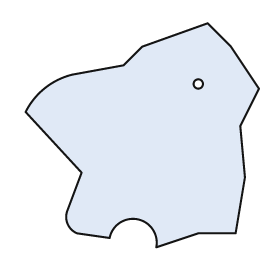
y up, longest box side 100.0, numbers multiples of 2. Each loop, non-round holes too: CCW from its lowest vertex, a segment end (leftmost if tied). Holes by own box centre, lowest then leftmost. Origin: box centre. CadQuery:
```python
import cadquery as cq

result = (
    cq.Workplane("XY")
    .moveTo(6.0, -48.0)
    .lineTo(24.0, -42.0)
    .lineTo(40.0, -42.0)
    .lineTo(44.0, -18.0)
    .lineTo(42.0, 4.0)
    .lineTo(50.0, 20.0)
    .lineTo(38.0, 38.0)
    .lineTo(28.0, 48.0)
    .lineTo(0.0, 38.0)
    .lineTo(-8.0, 30.0)
    .lineTo(-30.0, 26.0)
    .threePointArc((-42.0, 20.0), (-50.0, 10.0))
    .lineTo(-26.0, -16.0)
    .lineTo(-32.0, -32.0)
    .threePointArc((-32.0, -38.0), (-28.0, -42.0))
    .lineTo(-14.0, -44.0)
    .threePointArc((-2.0, -36.0), (6.0, -48.0))
    .close()
    .moveTo(24.0, 22.0)
    .circle(2.0)
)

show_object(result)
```